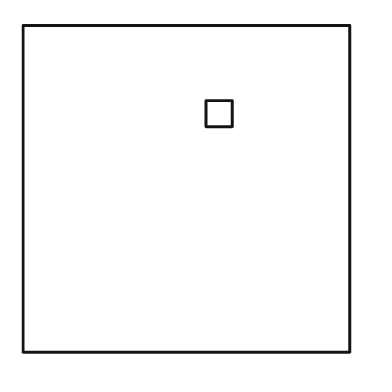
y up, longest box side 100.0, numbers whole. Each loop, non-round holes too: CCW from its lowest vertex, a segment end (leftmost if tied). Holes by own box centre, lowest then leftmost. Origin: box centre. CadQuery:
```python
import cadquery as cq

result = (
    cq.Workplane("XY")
    .moveTo(-50.0, -50.0)
    .lineTo(50.0, -50.0)
    .lineTo(50.0, 50.0)
    .lineTo(-50.0, 50.0)
    .close()
    .moveTo(6.0, 19.0)
    .lineTo(14.0, 19.0)
    .lineTo(14.0, 27.0)
    .lineTo(6.0, 27.0)
    .close()
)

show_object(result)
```